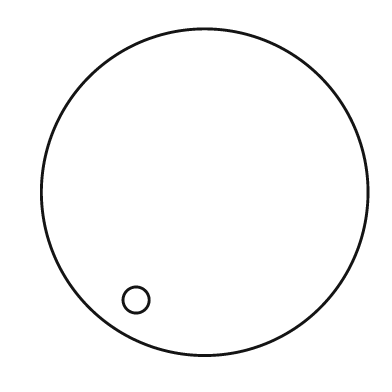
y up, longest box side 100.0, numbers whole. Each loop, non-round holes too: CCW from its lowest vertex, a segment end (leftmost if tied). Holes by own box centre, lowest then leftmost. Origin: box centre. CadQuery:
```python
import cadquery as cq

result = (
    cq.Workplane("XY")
    .moveTo(0.0, 0.0)
    .circle(50.0)
    .moveTo(-21.0, -33.0)
    .circle(4.0)
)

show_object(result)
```